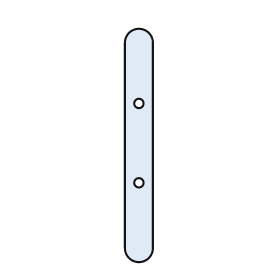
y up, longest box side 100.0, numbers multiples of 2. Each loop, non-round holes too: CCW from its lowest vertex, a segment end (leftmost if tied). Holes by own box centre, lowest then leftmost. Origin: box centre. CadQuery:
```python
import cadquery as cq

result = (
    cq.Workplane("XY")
    .moveTo(-6.0, -44.0)
    .threePointArc((0.0, -50.0), (6.0, -44.0))
    .lineTo(6.0, 44.0)
    .threePointArc((0.0, 50.0), (-6.0, 44.0))
    .close()
    .moveTo(0.0, -16.0)
    .circle(2.0)
    .moveTo(0.0, 18.0)
    .circle(2.0)
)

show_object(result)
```